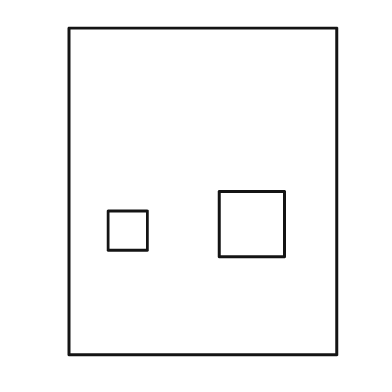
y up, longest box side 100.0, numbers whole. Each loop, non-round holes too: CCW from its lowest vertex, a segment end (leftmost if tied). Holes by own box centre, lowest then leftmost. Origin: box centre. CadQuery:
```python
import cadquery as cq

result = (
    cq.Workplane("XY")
    .moveTo(-41.0, -50.0)
    .lineTo(41.0, -50.0)
    .lineTo(41.0, 50.0)
    .lineTo(-41.0, 50.0)
    .close()
    .moveTo(-29.0, -18.0)
    .lineTo(-17.0, -18.0)
    .lineTo(-17.0, -6.0)
    .lineTo(-29.0, -6.0)
    .close()
    .moveTo(5.0, -20.0)
    .lineTo(25.0, -20.0)
    .lineTo(25.0, 0.0)
    .lineTo(5.0, 0.0)
    .close()
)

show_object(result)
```